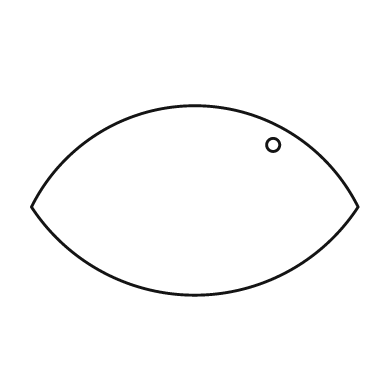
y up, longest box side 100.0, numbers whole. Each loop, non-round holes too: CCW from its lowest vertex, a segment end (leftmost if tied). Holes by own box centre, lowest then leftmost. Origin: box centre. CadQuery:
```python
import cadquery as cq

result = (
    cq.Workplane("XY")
    .moveTo(-50.0, -2.0)
    .threePointArc((0.0, -29.0), (50.0, -2.0))
    .threePointArc((0.0, 29.0), (-50.0, -2.0))
    .close()
    .moveTo(24.0, 17.0)
    .circle(2.0)
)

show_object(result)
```